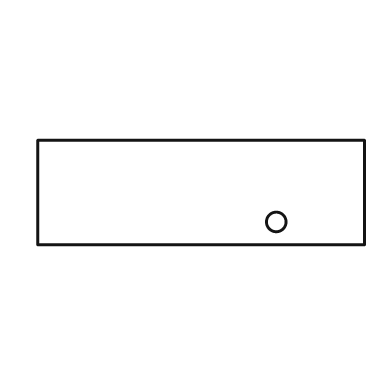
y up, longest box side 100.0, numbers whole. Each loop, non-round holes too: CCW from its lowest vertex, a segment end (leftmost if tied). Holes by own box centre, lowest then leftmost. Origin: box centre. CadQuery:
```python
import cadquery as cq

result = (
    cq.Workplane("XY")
    .moveTo(-50.0, -16.0)
    .lineTo(50.0, -16.0)
    .lineTo(50.0, 16.0)
    .lineTo(-50.0, 16.0)
    .close()
    .moveTo(23.0, -9.0)
    .circle(3.0)
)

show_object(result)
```